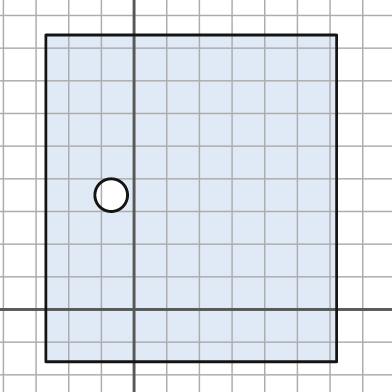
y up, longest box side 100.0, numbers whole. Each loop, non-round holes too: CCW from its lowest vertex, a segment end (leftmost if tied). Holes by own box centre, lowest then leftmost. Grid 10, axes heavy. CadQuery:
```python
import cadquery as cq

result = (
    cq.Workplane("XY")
    .moveTo(-27.0, -16.0)
    .lineTo(62.0, -16.0)
    .lineTo(62.0, 84.0)
    .lineTo(-27.0, 84.0)
    .close()
    .moveTo(-7.0, 35.0)
    .circle(5.0)
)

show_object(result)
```